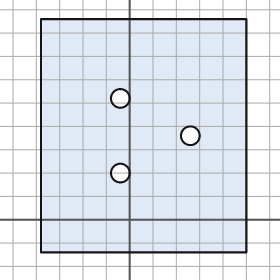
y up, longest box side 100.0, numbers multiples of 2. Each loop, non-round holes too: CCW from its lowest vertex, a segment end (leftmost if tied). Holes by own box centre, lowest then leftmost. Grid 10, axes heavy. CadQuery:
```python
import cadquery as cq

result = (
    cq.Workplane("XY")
    .moveTo(-38.0, -14.0)
    .lineTo(50.0, -14.0)
    .lineTo(50.0, 86.0)
    .lineTo(-38.0, 86.0)
    .close()
    .moveTo(-4.0, 20.0)
    .circle(4.0)
    .moveTo(26.0, 36.0)
    .circle(4.0)
    .moveTo(-4.0, 52.0)
    .circle(4.0)
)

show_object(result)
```